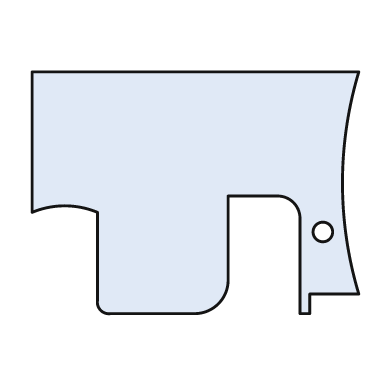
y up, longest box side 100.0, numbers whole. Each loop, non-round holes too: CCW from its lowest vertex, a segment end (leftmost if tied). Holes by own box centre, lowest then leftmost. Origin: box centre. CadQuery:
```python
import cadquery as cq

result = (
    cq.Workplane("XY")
    .moveTo(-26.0, -37.0)
    .lineTo(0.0, -37.0)
    .threePointArc((7.0, -34.0), (10.0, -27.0))
    .lineTo(10.0, -1.0)
    .lineTo(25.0, -1.0)
    .threePointArc((30.0, -3.0), (32.0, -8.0))
    .lineTo(32.0, -37.0)
    .lineTo(35.0, -37.0)
    .lineTo(35.0, -31.0)
    .lineTo(50.0, -31.0)
    .threePointArc((45.0, 3.0), (50.0, 37.0))
    .lineTo(-50.0, 37.0)
    .lineTo(-50.0, -6.0)
    .threePointArc((-40.0, -4.0), (-30.0, -6.0))
    .lineTo(-30.0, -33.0)
    .threePointArc((-29.0, -36.0), (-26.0, -37.0))
    .close()
    .moveTo(39.0, -12.0)
    .circle(3.0)
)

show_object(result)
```